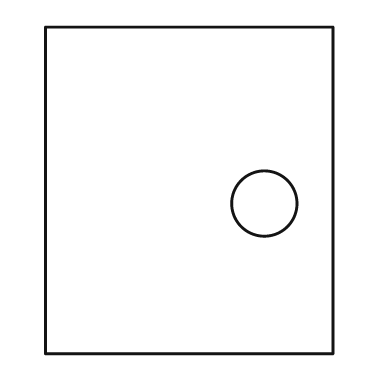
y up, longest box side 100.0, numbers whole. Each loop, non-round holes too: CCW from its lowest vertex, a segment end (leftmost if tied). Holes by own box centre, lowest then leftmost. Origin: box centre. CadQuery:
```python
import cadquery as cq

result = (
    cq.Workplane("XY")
    .moveTo(-44.0, -50.0)
    .lineTo(44.0, -50.0)
    .lineTo(44.0, 50.0)
    .lineTo(-44.0, 50.0)
    .close()
    .moveTo(23.0, -4.0)
    .circle(10.0)
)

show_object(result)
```